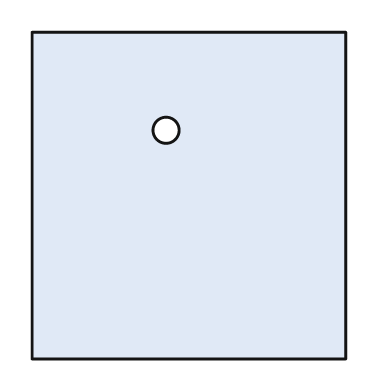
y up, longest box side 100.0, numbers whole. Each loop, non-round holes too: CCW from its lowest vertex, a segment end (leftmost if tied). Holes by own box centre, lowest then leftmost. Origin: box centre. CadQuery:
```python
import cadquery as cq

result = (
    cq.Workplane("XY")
    .moveTo(-48.0, -50.0)
    .lineTo(48.0, -50.0)
    .lineTo(48.0, 50.0)
    .lineTo(-48.0, 50.0)
    .close()
    .moveTo(-7.0, 20.0)
    .circle(4.0)
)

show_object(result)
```